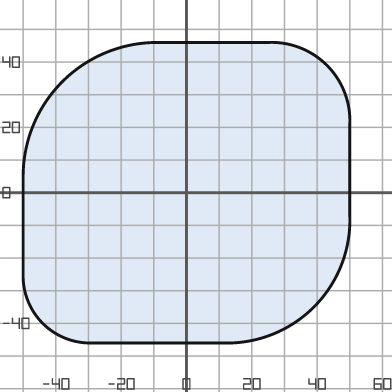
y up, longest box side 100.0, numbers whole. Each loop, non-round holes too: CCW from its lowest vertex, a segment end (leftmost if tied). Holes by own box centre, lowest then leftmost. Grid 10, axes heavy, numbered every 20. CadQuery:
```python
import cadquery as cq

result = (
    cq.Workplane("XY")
    .moveTo(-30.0, -46.0)
    .lineTo(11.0, -46.0)
    .threePointArc((39.0, -35.0), (50.0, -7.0))
    .lineTo(50.0, 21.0)
    .threePointArc((43.0, 39.0), (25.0, 46.0))
    .lineTo(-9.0, 46.0)
    .threePointArc((-38.0, 34.0), (-50.0, 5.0))
    .lineTo(-50.0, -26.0)
    .threePointArc((-44.0, -40.0), (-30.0, -46.0))
    .close()
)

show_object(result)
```